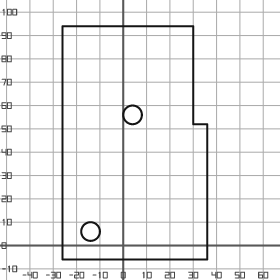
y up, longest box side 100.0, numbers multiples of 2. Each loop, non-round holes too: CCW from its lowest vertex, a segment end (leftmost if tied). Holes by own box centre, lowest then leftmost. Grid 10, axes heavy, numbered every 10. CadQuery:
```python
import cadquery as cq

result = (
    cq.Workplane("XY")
    .moveTo(-26.0, -6.0)
    .lineTo(36.0, -6.0)
    .lineTo(36.0, 52.0)
    .lineTo(30.0, 52.0)
    .lineTo(30.0, 94.0)
    .lineTo(-26.0, 94.0)
    .close()
    .moveTo(-14.0, 6.0)
    .circle(4.0)
    .moveTo(4.0, 56.0)
    .circle(4.0)
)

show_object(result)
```